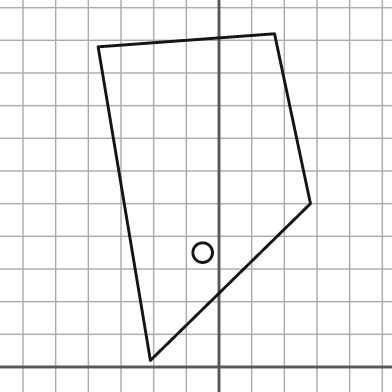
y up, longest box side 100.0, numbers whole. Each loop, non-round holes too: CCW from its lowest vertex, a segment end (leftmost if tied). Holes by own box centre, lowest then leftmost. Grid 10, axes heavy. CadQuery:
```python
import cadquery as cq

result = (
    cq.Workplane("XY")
    .moveTo(-21.0, 2.0)
    .lineTo(28.0, 50.0)
    .lineTo(17.0, 102.0)
    .lineTo(-37.0, 98.0)
    .close()
    .moveTo(-5.0, 35.0)
    .circle(3.0)
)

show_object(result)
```